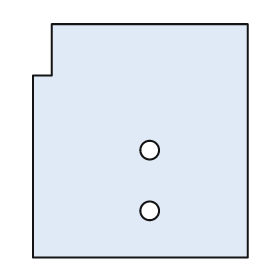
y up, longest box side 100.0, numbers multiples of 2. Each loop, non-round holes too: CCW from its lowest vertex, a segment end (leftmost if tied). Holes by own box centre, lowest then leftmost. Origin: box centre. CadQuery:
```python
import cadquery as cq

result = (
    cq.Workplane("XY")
    .moveTo(-46.0, -50.0)
    .lineTo(46.0, -50.0)
    .lineTo(46.0, 50.0)
    .lineTo(-38.0, 50.0)
    .lineTo(-38.0, 28.0)
    .lineTo(-46.0, 28.0)
    .close()
    .moveTo(4.0, -30.0)
    .circle(4.0)
    .moveTo(4.0, -4.0)
    .circle(4.0)
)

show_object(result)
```